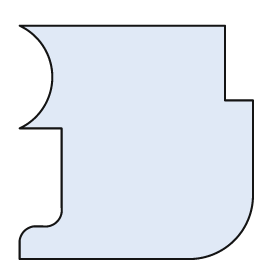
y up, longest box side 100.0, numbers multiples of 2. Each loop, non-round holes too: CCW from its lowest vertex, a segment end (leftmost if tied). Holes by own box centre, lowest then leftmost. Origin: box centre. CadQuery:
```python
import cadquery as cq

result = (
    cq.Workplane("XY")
    .moveTo(-50.0, -50.0)
    .lineTo(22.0, -50.0)
    .threePointArc((42.0, -42.0), (50.0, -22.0))
    .lineTo(50.0, 18.0)
    .lineTo(38.0, 18.0)
    .lineTo(38.0, 50.0)
    .lineTo(-50.0, 50.0)
    .threePointArc((-36.0, 28.0), (-50.0, 6.0))
    .lineTo(-32.0, 6.0)
    .lineTo(-32.0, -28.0)
    .threePointArc((-34.0, -34.0), (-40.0, -36.0))
    .lineTo(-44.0, -36.0)
    .threePointArc((-48.0, -38.0), (-50.0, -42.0))
    .close()
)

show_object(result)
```